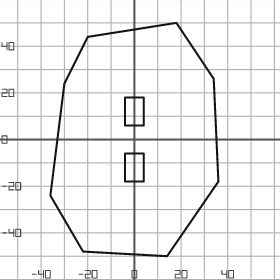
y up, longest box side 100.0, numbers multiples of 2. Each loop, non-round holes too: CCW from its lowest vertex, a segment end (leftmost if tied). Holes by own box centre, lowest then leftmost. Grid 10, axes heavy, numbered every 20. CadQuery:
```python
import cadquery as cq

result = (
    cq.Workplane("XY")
    .moveTo(14.0, -50.0)
    .lineTo(36.0, -18.0)
    .lineTo(34.0, 26.0)
    .lineTo(18.0, 50.0)
    .lineTo(-20.0, 44.0)
    .lineTo(-30.0, 24.0)
    .lineTo(-36.0, -24.0)
    .lineTo(-22.0, -48.0)
    .close()
    .moveTo(-4.0, -18.0)
    .lineTo(4.0, -18.0)
    .lineTo(4.0, -6.0)
    .lineTo(-4.0, -6.0)
    .close()
    .moveTo(-4.0, 6.0)
    .lineTo(4.0, 6.0)
    .lineTo(4.0, 18.0)
    .lineTo(-4.0, 18.0)
    .close()
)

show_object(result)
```